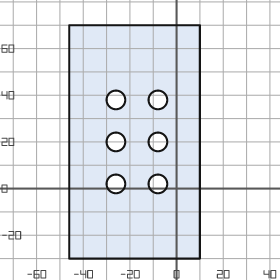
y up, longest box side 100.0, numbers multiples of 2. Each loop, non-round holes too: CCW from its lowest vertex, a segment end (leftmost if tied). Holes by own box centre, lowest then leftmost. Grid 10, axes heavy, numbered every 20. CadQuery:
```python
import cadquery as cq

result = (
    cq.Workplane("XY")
    .moveTo(-46.0, -30.0)
    .lineTo(10.0, -30.0)
    .lineTo(10.0, 70.0)
    .lineTo(-46.0, 70.0)
    .close()
    .moveTo(-26.0, 2.0)
    .circle(4.0)
    .moveTo(-8.0, 2.0)
    .circle(4.0)
    .moveTo(-26.0, 20.0)
    .circle(4.0)
    .moveTo(-8.0, 20.0)
    .circle(4.0)
    .moveTo(-26.0, 38.0)
    .circle(4.0)
    .moveTo(-8.0, 38.0)
    .circle(4.0)
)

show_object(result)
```